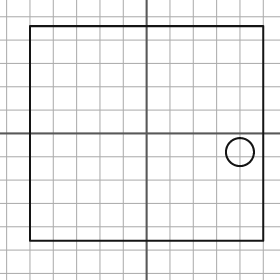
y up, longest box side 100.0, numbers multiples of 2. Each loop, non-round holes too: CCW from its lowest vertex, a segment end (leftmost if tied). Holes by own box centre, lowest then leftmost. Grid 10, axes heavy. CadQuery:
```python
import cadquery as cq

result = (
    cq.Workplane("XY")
    .moveTo(-50.0, -46.0)
    .lineTo(50.0, -46.0)
    .lineTo(50.0, 46.0)
    .lineTo(-50.0, 46.0)
    .close()
    .moveTo(40.0, -8.0)
    .circle(6.0)
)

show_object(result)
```